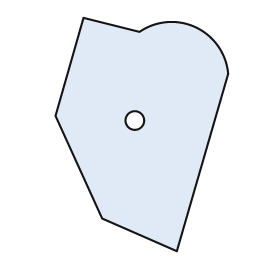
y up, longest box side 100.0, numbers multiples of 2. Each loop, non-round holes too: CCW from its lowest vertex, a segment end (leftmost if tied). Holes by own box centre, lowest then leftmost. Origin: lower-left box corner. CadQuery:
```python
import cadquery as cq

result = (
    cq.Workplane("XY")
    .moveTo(52.0, 0.0)
    .lineTo(74.0, 76.0)
    .threePointArc((60.0, 96.0), (36.0, 94.0))
    .lineTo(12.0, 100.0)
    .lineTo(0.0, 58.0)
    .lineTo(20.0, 14.0)
    .close()
    .moveTo(34.0, 56.0)
    .circle(4.0)
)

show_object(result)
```